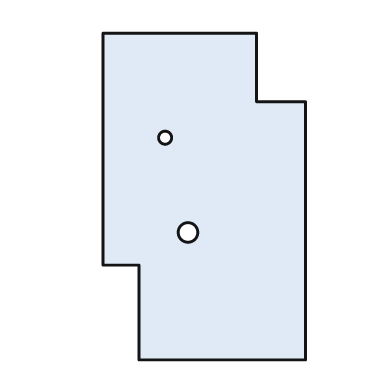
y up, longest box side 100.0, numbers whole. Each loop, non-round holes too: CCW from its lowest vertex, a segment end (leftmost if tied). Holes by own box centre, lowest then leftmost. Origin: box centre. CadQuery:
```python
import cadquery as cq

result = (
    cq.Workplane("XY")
    .moveTo(-20.0, -50.0)
    .lineTo(31.0, -50.0)
    .lineTo(31.0, 29.0)
    .lineTo(16.0, 29.0)
    .lineTo(16.0, 50.0)
    .lineTo(-31.0, 50.0)
    .lineTo(-31.0, -21.0)
    .lineTo(-20.0, -21.0)
    .close()
    .moveTo(-5.0, -11.0)
    .circle(3.0)
    .moveTo(-12.0, 18.0)
    .circle(2.0)
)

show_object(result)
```